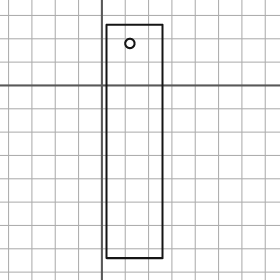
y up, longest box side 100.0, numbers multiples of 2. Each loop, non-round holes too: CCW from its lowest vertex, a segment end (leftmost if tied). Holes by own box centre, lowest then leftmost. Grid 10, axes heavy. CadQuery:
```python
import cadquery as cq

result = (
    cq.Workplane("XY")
    .moveTo(2.0, -74.0)
    .lineTo(26.0, -74.0)
    .lineTo(26.0, 26.0)
    .lineTo(2.0, 26.0)
    .close()
    .moveTo(12.0, 18.0)
    .circle(2.0)
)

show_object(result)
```